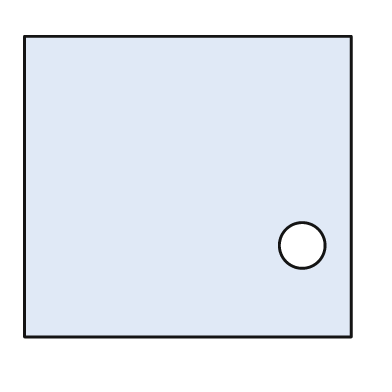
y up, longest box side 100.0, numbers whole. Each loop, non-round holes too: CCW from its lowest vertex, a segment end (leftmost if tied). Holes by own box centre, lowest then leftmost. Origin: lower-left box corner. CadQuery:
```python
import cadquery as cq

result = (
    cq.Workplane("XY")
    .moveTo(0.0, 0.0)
    .lineTo(100.0, 0.0)
    .lineTo(100.0, 92.0)
    .lineTo(0.0, 92.0)
    .close()
    .moveTo(85.0, 28.0)
    .circle(7.0)
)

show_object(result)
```